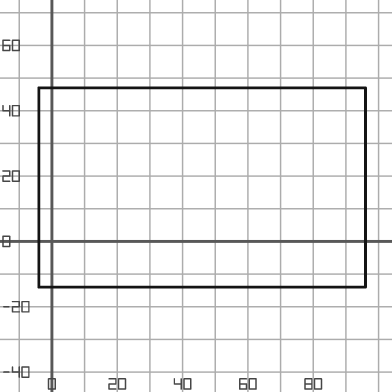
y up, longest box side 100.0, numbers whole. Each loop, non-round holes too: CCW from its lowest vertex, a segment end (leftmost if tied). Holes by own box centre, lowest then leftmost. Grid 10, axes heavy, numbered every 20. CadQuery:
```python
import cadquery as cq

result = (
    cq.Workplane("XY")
    .moveTo(-4.0, -14.0)
    .lineTo(96.0, -14.0)
    .lineTo(96.0, 47.0)
    .lineTo(-4.0, 47.0)
    .close()
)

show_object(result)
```